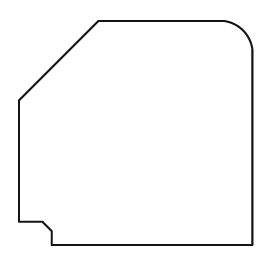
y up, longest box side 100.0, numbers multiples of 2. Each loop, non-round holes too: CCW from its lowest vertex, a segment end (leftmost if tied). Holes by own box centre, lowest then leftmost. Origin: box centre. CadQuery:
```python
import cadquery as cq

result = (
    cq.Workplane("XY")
    .moveTo(-36.0, -48.0)
    .lineTo(50.0, -48.0)
    .lineTo(50.0, 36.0)
    .threePointArc((46.0, 44.0), (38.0, 48.0))
    .lineTo(-16.0, 48.0)
    .lineTo(-50.0, 14.0)
    .lineTo(-50.0, -38.0)
    .lineTo(-40.0, -38.0)
    .lineTo(-36.0, -42.0)
    .close()
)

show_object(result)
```